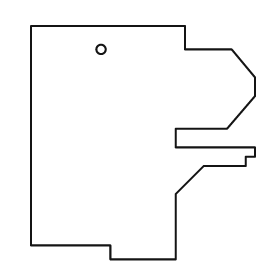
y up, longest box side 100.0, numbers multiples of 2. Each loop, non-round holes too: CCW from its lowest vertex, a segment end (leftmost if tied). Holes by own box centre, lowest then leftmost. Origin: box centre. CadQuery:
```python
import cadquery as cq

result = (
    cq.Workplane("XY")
    .moveTo(-14.0, -50.0)
    .lineTo(14.0, -50.0)
    .lineTo(14.0, -22.0)
    .lineTo(26.0, -10.0)
    .lineTo(44.0, -10.0)
    .lineTo(44.0, -6.0)
    .lineTo(48.0, -6.0)
    .lineTo(48.0, -2.0)
    .lineTo(14.0, -2.0)
    .lineTo(14.0, 6.0)
    .lineTo(36.0, 6.0)
    .lineTo(48.0, 20.0)
    .lineTo(48.0, 28.0)
    .lineTo(38.0, 40.0)
    .lineTo(18.0, 40.0)
    .lineTo(18.0, 50.0)
    .lineTo(-48.0, 50.0)
    .lineTo(-48.0, -44.0)
    .lineTo(-14.0, -44.0)
    .close()
    .moveTo(-18.0, 40.0)
    .circle(2.0)
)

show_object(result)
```